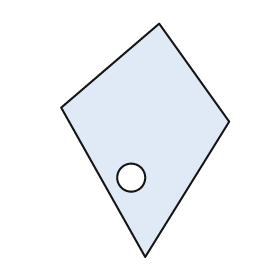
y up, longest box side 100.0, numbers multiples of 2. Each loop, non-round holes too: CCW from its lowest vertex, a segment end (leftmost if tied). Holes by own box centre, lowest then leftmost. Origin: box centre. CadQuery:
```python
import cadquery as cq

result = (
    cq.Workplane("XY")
    .moveTo(0.0, -50.0)
    .lineTo(36.0, 8.0)
    .lineTo(6.0, 50.0)
    .lineTo(-36.0, 14.0)
    .close()
    .moveTo(-6.0, -16.0)
    .circle(6.0)
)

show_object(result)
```